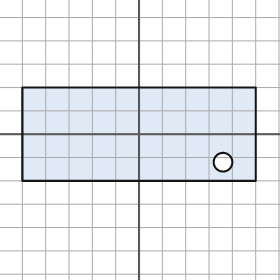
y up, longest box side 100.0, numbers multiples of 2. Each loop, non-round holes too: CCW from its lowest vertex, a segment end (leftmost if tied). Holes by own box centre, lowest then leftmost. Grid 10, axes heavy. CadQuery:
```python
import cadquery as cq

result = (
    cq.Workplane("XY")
    .moveTo(-50.0, -20.0)
    .lineTo(50.0, -20.0)
    .lineTo(50.0, 20.0)
    .lineTo(-50.0, 20.0)
    .close()
    .moveTo(36.0, -12.0)
    .circle(4.0)
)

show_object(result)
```